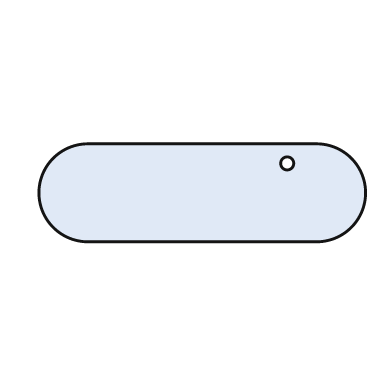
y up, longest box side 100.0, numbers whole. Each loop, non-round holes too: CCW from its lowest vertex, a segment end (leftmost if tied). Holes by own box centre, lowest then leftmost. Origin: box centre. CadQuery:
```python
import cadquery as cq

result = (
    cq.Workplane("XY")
    .moveTo(-35.0, -15.0)
    .lineTo(35.0, -15.0)
    .threePointArc((50.0, 0.0), (35.0, 15.0))
    .lineTo(-35.0, 15.0)
    .threePointArc((-50.0, 0.0), (-35.0, -15.0))
    .close()
    .moveTo(26.0, 9.0)
    .circle(2.0)
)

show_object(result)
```